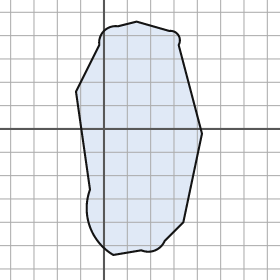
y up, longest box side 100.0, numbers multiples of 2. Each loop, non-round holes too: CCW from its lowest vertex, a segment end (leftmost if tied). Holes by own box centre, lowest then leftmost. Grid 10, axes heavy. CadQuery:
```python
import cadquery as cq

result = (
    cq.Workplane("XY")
    .moveTo(4.0, -54.0)
    .lineTo(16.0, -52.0)
    .threePointArc((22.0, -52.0), (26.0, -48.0))
    .lineTo(34.0, -40.0)
    .lineTo(42.0, -2.0)
    .lineTo(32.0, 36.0)
    .threePointArc((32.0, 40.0), (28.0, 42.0))
    .lineTo(14.0, 46.0)
    .lineTo(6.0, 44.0)
    .threePointArc((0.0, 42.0), (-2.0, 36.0))
    .lineTo(-12.0, 16.0)
    .lineTo(-6.0, -26.0)
    .threePointArc((-6.0, -42.0), (4.0, -54.0))
    .close()
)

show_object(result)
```